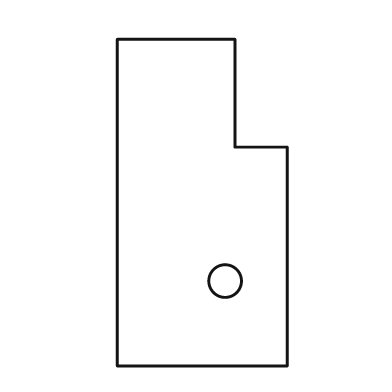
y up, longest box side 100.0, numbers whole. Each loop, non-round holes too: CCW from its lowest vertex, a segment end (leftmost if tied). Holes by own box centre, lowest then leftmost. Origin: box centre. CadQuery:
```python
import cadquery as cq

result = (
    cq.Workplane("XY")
    .moveTo(-26.0, -50.0)
    .lineTo(26.0, -50.0)
    .lineTo(26.0, 17.0)
    .lineTo(10.0, 17.0)
    .lineTo(10.0, 50.0)
    .lineTo(-26.0, 50.0)
    .close()
    .moveTo(7.0, -24.0)
    .circle(5.0)
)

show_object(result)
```